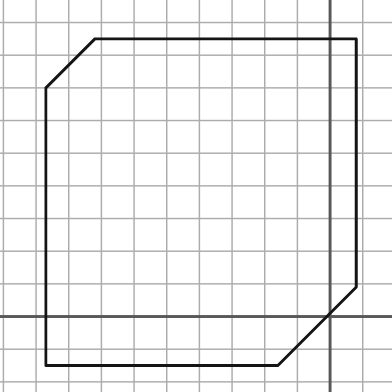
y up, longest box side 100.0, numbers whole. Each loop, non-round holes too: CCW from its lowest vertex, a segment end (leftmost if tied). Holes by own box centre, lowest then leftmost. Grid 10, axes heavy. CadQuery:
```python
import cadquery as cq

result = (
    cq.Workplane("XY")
    .moveTo(-87.0, -15.0)
    .lineTo(-16.0, -15.0)
    .lineTo(8.0, 9.0)
    .lineTo(8.0, 85.0)
    .lineTo(-72.0, 85.0)
    .lineTo(-87.0, 70.0)
    .close()
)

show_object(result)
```